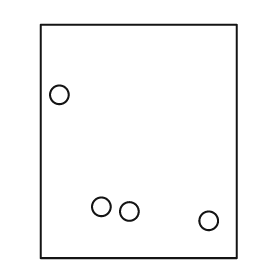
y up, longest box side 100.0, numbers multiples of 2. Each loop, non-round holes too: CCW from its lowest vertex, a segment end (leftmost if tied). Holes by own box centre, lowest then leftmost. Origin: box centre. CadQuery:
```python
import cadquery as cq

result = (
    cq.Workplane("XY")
    .moveTo(-42.0, -50.0)
    .lineTo(42.0, -50.0)
    .lineTo(42.0, 50.0)
    .lineTo(-42.0, 50.0)
    .close()
    .moveTo(30.0, -34.0)
    .circle(4.0)
    .moveTo(-4.0, -30.0)
    .circle(4.0)
    .moveTo(-16.0, -28.0)
    .circle(4.0)
    .moveTo(-34.0, 20.0)
    .circle(4.0)
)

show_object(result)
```